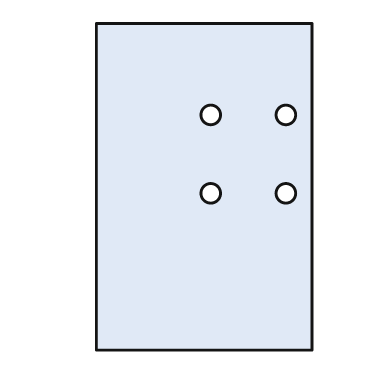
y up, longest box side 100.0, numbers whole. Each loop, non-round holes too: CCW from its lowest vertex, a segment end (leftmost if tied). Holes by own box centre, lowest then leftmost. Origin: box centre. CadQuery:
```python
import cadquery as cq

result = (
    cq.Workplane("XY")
    .moveTo(-33.0, -50.0)
    .lineTo(33.0, -50.0)
    .lineTo(33.0, 50.0)
    .lineTo(-33.0, 50.0)
    .close()
    .moveTo(2.0, -2.0)
    .circle(3.0)
    .moveTo(25.0, -2.0)
    .circle(3.0)
    .moveTo(2.0, 22.0)
    .circle(3.0)
    .moveTo(25.0, 22.0)
    .circle(3.0)
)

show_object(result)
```